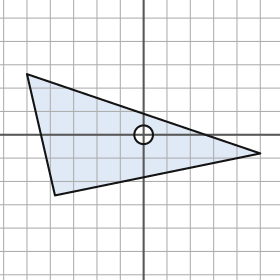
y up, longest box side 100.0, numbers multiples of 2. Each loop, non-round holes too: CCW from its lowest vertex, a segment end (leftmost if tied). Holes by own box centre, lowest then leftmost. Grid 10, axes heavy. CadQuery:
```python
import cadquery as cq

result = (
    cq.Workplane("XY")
    .moveTo(-38.0, -26.0)
    .lineTo(50.0, -8.0)
    .lineTo(-50.0, 26.0)
    .close()
    .moveTo(0.0, 0.0)
    .circle(4.0)
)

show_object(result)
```